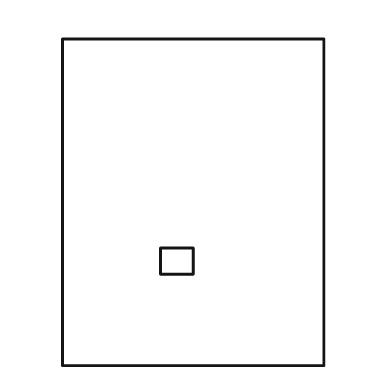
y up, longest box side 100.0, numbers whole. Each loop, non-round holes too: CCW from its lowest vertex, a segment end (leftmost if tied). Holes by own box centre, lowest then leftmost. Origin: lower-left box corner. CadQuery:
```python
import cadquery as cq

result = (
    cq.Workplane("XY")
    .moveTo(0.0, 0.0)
    .lineTo(80.0, 0.0)
    .lineTo(80.0, 100.0)
    .lineTo(0.0, 100.0)
    .close()
    .moveTo(30.0, 28.0)
    .lineTo(40.0, 28.0)
    .lineTo(40.0, 36.0)
    .lineTo(30.0, 36.0)
    .close()
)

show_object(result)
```